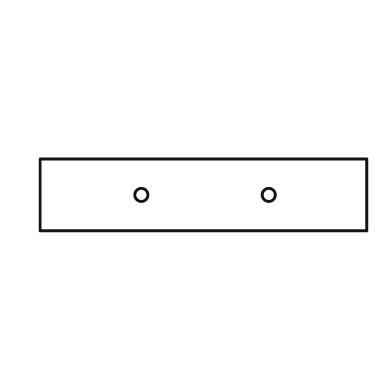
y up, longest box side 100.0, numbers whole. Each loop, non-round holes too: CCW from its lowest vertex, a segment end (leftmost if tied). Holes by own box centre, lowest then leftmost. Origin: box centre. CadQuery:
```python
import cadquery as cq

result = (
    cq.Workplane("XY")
    .moveTo(-50.0, -11.0)
    .lineTo(50.0, -11.0)
    .lineTo(50.0, 11.0)
    .lineTo(-50.0, 11.0)
    .close()
    .moveTo(-19.0, 0.0)
    .circle(2.0)
    .moveTo(20.0, 0.0)
    .circle(2.0)
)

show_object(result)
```